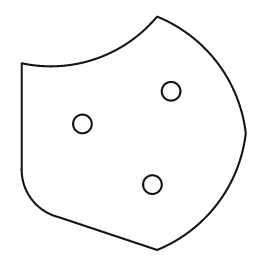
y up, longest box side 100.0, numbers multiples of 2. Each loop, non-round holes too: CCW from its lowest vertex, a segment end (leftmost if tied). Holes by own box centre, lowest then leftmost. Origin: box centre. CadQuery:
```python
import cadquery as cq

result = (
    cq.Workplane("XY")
    .moveTo(10.0, -50.0)
    .threePointArc((36.0, -30.0), (48.0, 0.0))
    .threePointArc((36.0, 30.0), (10.0, 50.0))
    .threePointArc((-16.0, 32.0), (-48.0, 30.0))
    .lineTo(-48.0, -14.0)
    .threePointArc((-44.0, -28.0), (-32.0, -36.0))
    .close()
    .moveTo(8.0, -22.0)
    .circle(4.0)
    .moveTo(-22.0, 4.0)
    .circle(4.0)
    .moveTo(16.0, 18.0)
    .circle(4.0)
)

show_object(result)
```